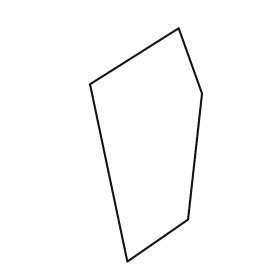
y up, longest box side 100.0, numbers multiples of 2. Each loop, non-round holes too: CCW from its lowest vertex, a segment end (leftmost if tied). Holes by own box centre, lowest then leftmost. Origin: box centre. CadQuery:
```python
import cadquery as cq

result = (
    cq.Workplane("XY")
    .moveTo(-8.0, -50.0)
    .lineTo(18.0, -32.0)
    .lineTo(24.0, 22.0)
    .lineTo(14.0, 50.0)
    .lineTo(-24.0, 26.0)
    .close()
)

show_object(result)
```